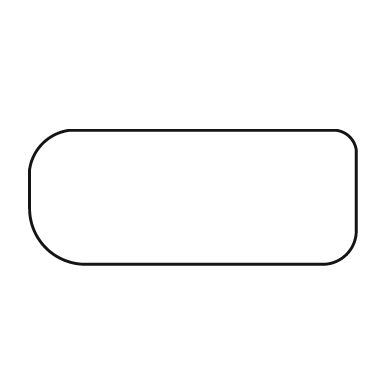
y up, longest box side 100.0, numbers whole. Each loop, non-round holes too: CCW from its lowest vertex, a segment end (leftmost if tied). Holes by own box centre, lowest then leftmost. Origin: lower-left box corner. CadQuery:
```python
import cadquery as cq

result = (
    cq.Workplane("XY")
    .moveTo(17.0, 0.0)
    .lineTo(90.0, 0.0)
    .threePointArc((97.0, 3.0), (100.0, 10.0))
    .lineTo(100.0, 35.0)
    .threePointArc((98.0, 39.0), (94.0, 41.0))
    .lineTo(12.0, 41.0)
    .threePointArc((4.0, 37.0), (0.0, 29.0))
    .lineTo(0.0, 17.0)
    .threePointArc((5.0, 5.0), (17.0, 0.0))
    .close()
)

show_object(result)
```